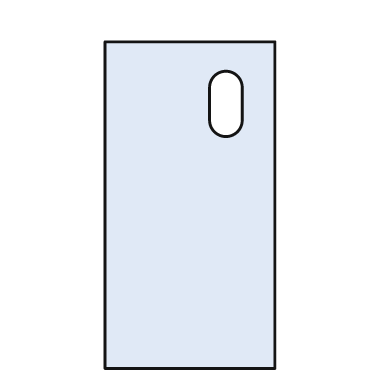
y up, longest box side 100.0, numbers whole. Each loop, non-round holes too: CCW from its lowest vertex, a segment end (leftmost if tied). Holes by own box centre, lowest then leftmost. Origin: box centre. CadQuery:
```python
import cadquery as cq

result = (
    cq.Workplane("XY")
    .moveTo(-26.0, -50.0)
    .lineTo(26.0, -50.0)
    .lineTo(26.0, 50.0)
    .lineTo(-26.0, 50.0)
    .close()
    .moveTo(6.0, 26.0)
    .threePointArc((11.0, 21.0), (16.0, 26.0))
    .lineTo(16.0, 36.0)
    .threePointArc((11.0, 41.0), (6.0, 36.0))
    .close()
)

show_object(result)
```